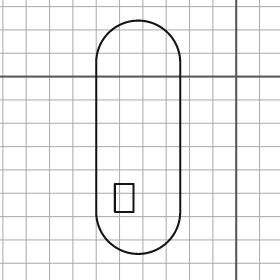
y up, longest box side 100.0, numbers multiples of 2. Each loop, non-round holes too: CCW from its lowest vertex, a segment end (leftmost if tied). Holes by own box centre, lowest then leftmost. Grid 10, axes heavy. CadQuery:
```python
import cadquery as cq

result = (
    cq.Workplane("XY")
    .moveTo(-60.0, -58.0)
    .threePointArc((-42.0, -76.0), (-24.0, -58.0))
    .lineTo(-24.0, 6.0)
    .threePointArc((-42.0, 24.0), (-60.0, 6.0))
    .close()
    .moveTo(-52.0, -58.0)
    .lineTo(-44.0, -58.0)
    .lineTo(-44.0, -46.0)
    .lineTo(-52.0, -46.0)
    .close()
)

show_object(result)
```